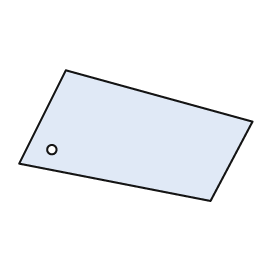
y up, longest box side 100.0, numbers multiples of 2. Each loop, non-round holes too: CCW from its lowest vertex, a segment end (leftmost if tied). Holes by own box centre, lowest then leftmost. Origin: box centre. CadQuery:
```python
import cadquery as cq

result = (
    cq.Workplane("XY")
    .moveTo(32.0, -28.0)
    .lineTo(50.0, 6.0)
    .lineTo(-30.0, 28.0)
    .lineTo(-50.0, -12.0)
    .close()
    .moveTo(-36.0, -6.0)
    .circle(2.0)
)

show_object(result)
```